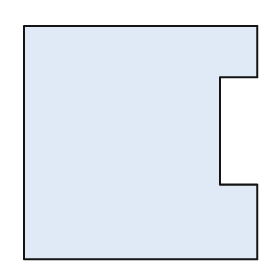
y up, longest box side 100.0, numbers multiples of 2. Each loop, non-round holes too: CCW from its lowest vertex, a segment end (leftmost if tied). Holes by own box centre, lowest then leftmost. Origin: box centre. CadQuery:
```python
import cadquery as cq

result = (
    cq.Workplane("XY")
    .moveTo(-50.0, -50.0)
    .lineTo(50.0, -50.0)
    .lineTo(50.0, -18.0)
    .lineTo(34.0, -18.0)
    .lineTo(34.0, 28.0)
    .lineTo(50.0, 28.0)
    .lineTo(50.0, 50.0)
    .lineTo(-50.0, 50.0)
    .close()
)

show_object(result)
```